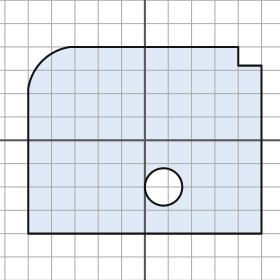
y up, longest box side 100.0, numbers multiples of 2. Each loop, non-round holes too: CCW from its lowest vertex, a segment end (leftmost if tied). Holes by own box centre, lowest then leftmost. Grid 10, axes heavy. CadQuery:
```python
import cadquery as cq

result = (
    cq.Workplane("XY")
    .moveTo(-50.0, -40.0)
    .lineTo(50.0, -40.0)
    .lineTo(50.0, 32.0)
    .lineTo(40.0, 32.0)
    .lineTo(40.0, 40.0)
    .lineTo(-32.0, 40.0)
    .threePointArc((-44.0, 34.0), (-50.0, 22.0))
    .close()
    .moveTo(8.0, -20.0)
    .circle(8.0)
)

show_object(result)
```